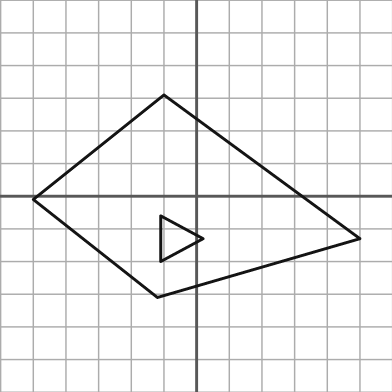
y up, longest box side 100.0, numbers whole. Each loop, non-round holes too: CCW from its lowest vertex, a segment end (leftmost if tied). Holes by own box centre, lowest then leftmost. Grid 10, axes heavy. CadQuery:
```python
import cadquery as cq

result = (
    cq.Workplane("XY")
    .moveTo(-12.0, -31.0)
    .lineTo(50.0, -13.0)
    .lineTo(-10.0, 31.0)
    .lineTo(-50.0, -1.0)
    .close()
    .moveTo(-11.0, -20.0)
    .lineTo(2.0, -13.0)
    .lineTo(-11.0, -6.0)
    .close()
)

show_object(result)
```